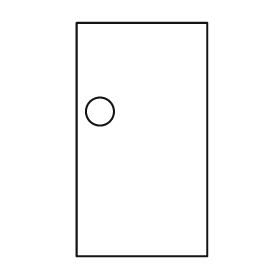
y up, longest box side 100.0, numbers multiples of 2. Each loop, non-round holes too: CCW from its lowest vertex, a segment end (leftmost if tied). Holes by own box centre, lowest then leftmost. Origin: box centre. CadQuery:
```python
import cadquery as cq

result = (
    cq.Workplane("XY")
    .moveTo(-28.0, -50.0)
    .lineTo(28.0, -50.0)
    .lineTo(28.0, 50.0)
    .lineTo(-28.0, 50.0)
    .close()
    .moveTo(-18.0, 12.0)
    .circle(6.0)
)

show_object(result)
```